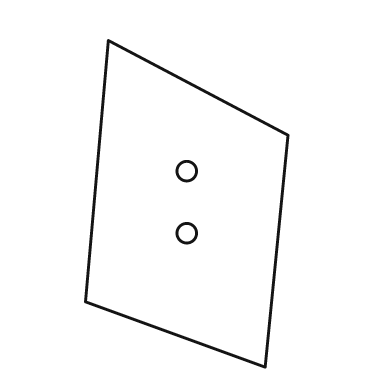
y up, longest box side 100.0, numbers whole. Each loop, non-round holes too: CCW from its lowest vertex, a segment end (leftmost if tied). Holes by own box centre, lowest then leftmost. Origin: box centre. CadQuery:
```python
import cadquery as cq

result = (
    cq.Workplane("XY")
    .moveTo(24.0, -50.0)
    .lineTo(31.0, 21.0)
    .lineTo(-24.0, 50.0)
    .lineTo(-31.0, -30.0)
    .close()
    .moveTo(0.0, -9.0)
    .circle(3.0)
    .moveTo(0.0, 10.0)
    .circle(3.0)
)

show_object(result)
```